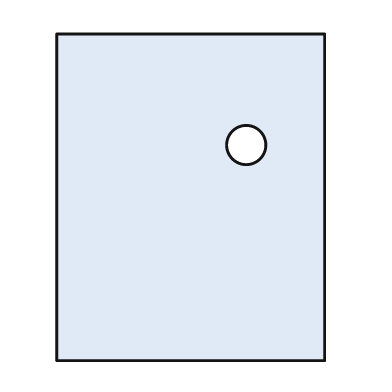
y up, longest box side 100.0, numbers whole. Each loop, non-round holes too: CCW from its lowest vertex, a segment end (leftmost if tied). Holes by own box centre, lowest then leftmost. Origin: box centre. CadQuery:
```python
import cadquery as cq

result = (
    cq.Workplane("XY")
    .moveTo(-41.0, -50.0)
    .lineTo(41.0, -50.0)
    .lineTo(41.0, 50.0)
    .lineTo(-41.0, 50.0)
    .close()
    .moveTo(17.0, 16.0)
    .circle(6.0)
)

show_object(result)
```